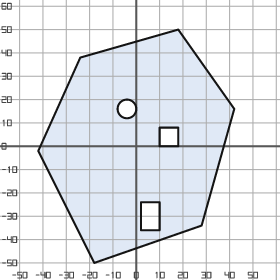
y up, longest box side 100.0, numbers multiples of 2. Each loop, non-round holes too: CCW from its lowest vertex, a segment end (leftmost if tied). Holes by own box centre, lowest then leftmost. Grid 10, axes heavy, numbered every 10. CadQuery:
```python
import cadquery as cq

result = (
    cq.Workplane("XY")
    .moveTo(-18.0, -50.0)
    .lineTo(28.0, -34.0)
    .lineTo(42.0, 16.0)
    .lineTo(18.0, 50.0)
    .lineTo(-24.0, 38.0)
    .lineTo(-42.0, -2.0)
    .close()
    .moveTo(2.0, -36.0)
    .lineTo(10.0, -36.0)
    .lineTo(10.0, -24.0)
    .lineTo(2.0, -24.0)
    .close()
    .moveTo(10.0, 0.0)
    .lineTo(18.0, 0.0)
    .lineTo(18.0, 8.0)
    .lineTo(10.0, 8.0)
    .close()
    .moveTo(-4.0, 16.0)
    .circle(4.0)
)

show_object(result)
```